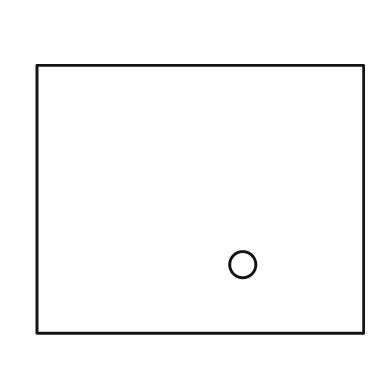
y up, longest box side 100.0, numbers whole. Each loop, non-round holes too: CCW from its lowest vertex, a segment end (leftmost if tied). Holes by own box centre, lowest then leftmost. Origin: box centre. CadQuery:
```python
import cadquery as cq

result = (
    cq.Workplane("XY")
    .moveTo(-50.0, -41.0)
    .lineTo(50.0, -41.0)
    .lineTo(50.0, 41.0)
    .lineTo(-50.0, 41.0)
    .close()
    .moveTo(13.0, -20.0)
    .circle(4.0)
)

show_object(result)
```